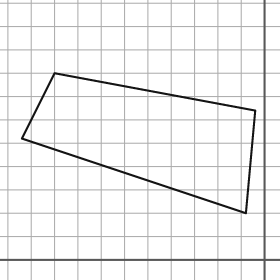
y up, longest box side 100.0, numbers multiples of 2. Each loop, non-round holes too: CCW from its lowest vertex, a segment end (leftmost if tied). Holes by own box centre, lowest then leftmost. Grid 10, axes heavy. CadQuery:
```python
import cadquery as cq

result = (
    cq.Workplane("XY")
    .moveTo(-8.0, 20.0)
    .lineTo(-4.0, 64.0)
    .lineTo(-90.0, 80.0)
    .lineTo(-104.0, 52.0)
    .close()
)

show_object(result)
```